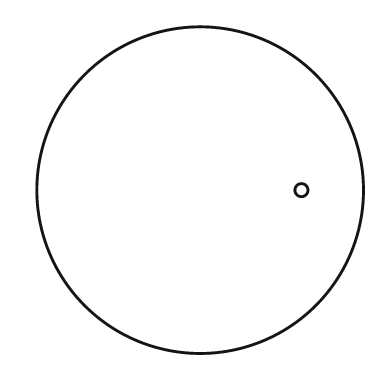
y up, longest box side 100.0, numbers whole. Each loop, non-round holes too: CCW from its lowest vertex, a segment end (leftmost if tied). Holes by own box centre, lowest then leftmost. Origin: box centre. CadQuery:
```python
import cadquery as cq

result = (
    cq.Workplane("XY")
    .moveTo(0.0, 0.0)
    .circle(50.0)
    .moveTo(31.0, 0.0)
    .circle(2.0)
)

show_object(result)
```